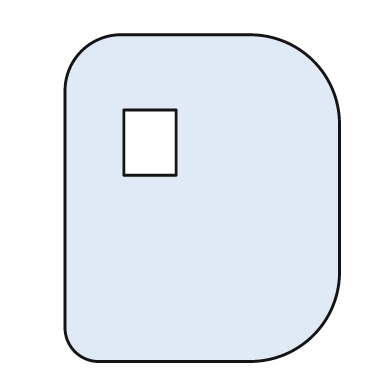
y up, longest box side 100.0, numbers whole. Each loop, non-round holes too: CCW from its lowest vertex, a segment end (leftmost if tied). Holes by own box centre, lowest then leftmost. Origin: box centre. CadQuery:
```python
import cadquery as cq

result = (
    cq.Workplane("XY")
    .moveTo(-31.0, -50.0)
    .lineTo(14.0, -50.0)
    .threePointArc((34.0, -42.0), (42.0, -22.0))
    .lineTo(42.0, 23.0)
    .threePointArc((34.0, 42.0), (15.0, 50.0))
    .lineTo(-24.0, 50.0)
    .threePointArc((-37.0, 45.0), (-42.0, 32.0))
    .lineTo(-42.0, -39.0)
    .threePointArc((-39.0, -47.0), (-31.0, -50.0))
    .close()
    .moveTo(-24.0, 7.0)
    .lineTo(-8.0, 7.0)
    .lineTo(-8.0, 27.0)
    .lineTo(-24.0, 27.0)
    .close()
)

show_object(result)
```